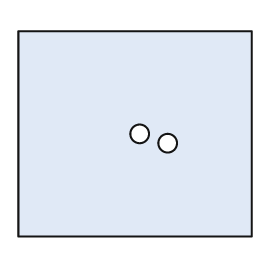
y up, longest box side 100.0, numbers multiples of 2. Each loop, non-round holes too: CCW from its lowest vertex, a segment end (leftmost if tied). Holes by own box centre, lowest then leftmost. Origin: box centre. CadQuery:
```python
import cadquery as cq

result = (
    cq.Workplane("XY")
    .moveTo(-50.0, -44.0)
    .lineTo(50.0, -44.0)
    .lineTo(50.0, 44.0)
    .lineTo(-50.0, 44.0)
    .close()
    .moveTo(14.0, -4.0)
    .circle(4.0)
    .moveTo(2.0, 0.0)
    .circle(4.0)
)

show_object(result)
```